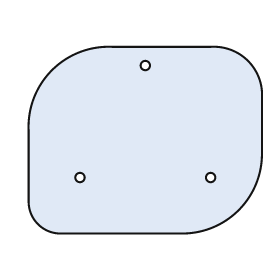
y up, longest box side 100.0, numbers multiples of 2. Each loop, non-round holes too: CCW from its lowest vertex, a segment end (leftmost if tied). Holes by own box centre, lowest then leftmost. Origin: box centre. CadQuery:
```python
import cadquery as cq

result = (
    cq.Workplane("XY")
    .moveTo(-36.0, -40.0)
    .lineTo(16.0, -40.0)
    .threePointArc((40.0, -30.0), (50.0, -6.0))
    .lineTo(50.0, 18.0)
    .threePointArc((44.0, 34.0), (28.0, 40.0))
    .lineTo(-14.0, 40.0)
    .threePointArc((-40.0, 30.0), (-50.0, 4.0))
    .lineTo(-50.0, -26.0)
    .threePointArc((-46.0, -36.0), (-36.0, -40.0))
    .close()
    .moveTo(-28.0, -16.0)
    .circle(2.0)
    .moveTo(28.0, -16.0)
    .circle(2.0)
    .moveTo(0.0, 32.0)
    .circle(2.0)
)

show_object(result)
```